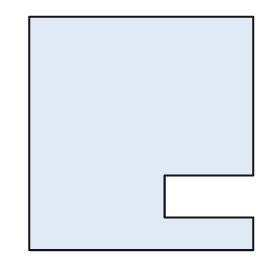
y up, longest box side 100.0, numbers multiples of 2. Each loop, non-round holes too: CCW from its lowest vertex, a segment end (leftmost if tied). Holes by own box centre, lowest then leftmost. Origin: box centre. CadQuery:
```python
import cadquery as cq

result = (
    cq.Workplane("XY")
    .moveTo(-48.0, -50.0)
    .lineTo(48.0, -50.0)
    .lineTo(48.0, -36.0)
    .lineTo(10.0, -36.0)
    .lineTo(10.0, -18.0)
    .lineTo(48.0, -18.0)
    .lineTo(48.0, 50.0)
    .lineTo(-48.0, 50.0)
    .close()
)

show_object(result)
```